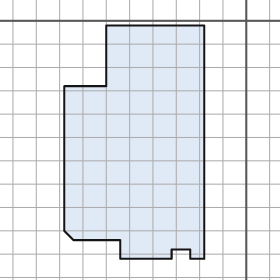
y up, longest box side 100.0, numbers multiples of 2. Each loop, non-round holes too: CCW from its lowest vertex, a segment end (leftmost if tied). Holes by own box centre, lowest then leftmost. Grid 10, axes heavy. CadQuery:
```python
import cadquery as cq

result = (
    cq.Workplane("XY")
    .moveTo(-54.0, -102.0)
    .lineTo(-32.0, -102.0)
    .lineTo(-32.0, -98.0)
    .lineTo(-24.0, -98.0)
    .lineTo(-24.0, -102.0)
    .lineTo(-18.0, -102.0)
    .lineTo(-18.0, -2.0)
    .lineTo(-60.0, -2.0)
    .lineTo(-60.0, -28.0)
    .lineTo(-78.0, -28.0)
    .lineTo(-78.0, -90.0)
    .lineTo(-74.0, -94.0)
    .lineTo(-54.0, -94.0)
    .close()
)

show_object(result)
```